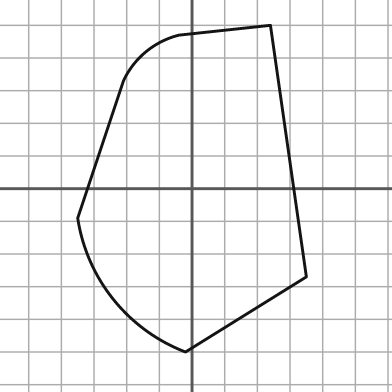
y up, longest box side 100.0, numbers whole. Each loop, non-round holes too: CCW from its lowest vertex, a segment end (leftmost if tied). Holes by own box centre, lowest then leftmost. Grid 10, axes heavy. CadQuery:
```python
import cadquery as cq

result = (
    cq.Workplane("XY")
    .moveTo(-2.0, -50.0)
    .lineTo(35.0, -27.0)
    .lineTo(24.0, 50.0)
    .lineTo(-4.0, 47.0)
    .threePointArc((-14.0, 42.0), (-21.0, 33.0))
    .lineTo(-35.0, -9.0)
    .threePointArc((-24.0, -34.0), (-2.0, -50.0))
    .close()
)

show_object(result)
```